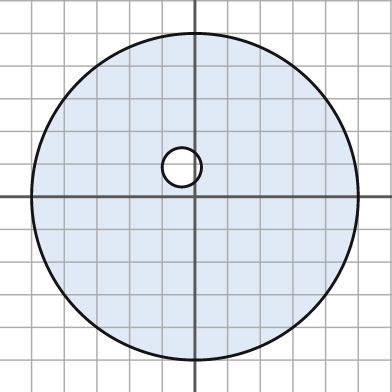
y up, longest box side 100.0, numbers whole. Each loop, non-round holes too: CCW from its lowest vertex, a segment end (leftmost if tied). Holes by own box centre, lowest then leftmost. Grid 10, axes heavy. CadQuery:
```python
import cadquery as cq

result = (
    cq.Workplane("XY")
    .moveTo(0.0, 0.0)
    .circle(50.0)
    .moveTo(-4.0, 9.0)
    .circle(6.0)
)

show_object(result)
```